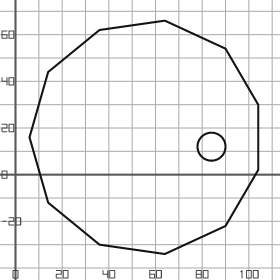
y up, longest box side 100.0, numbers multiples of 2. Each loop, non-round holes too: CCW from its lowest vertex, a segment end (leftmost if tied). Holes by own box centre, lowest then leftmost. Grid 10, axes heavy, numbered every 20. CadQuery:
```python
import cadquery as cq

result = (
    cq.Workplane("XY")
    .moveTo(64.0, -34.0)
    .lineTo(90.0, -22.0)
    .lineTo(104.0, 2.0)
    .lineTo(104.0, 30.0)
    .lineTo(90.0, 54.0)
    .lineTo(64.0, 66.0)
    .lineTo(36.0, 62.0)
    .lineTo(14.0, 44.0)
    .lineTo(6.0, 16.0)
    .lineTo(14.0, -12.0)
    .lineTo(36.0, -30.0)
    .close()
    .moveTo(84.0, 12.0)
    .circle(6.0)
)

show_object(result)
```